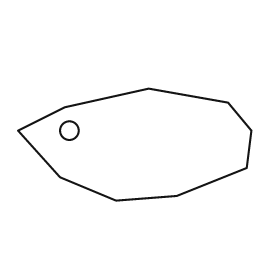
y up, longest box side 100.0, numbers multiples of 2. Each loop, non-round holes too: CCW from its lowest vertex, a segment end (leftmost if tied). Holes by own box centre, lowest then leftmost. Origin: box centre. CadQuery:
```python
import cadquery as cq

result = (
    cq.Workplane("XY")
    .moveTo(-8.0, -24.0)
    .lineTo(18.0, -22.0)
    .lineTo(48.0, -10.0)
    .lineTo(50.0, 6.0)
    .lineTo(40.0, 18.0)
    .lineTo(6.0, 24.0)
    .lineTo(-30.0, 16.0)
    .lineTo(-50.0, 6.0)
    .lineTo(-32.0, -14.0)
    .close()
    .moveTo(-28.0, 6.0)
    .circle(4.0)
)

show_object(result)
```